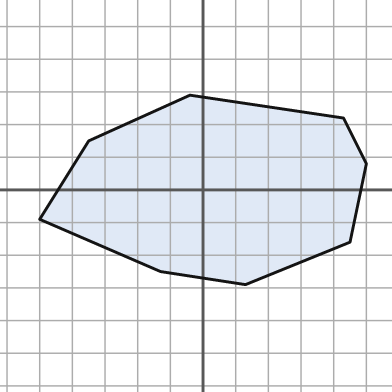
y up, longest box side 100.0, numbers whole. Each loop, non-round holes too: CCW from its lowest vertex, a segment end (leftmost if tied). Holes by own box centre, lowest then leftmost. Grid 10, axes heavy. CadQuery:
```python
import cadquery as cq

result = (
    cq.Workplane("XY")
    .moveTo(13.0, -29.0)
    .lineTo(45.0, -16.0)
    .lineTo(50.0, 8.0)
    .lineTo(43.0, 22.0)
    .lineTo(-4.0, 29.0)
    .lineTo(-35.0, 15.0)
    .lineTo(-50.0, -9.0)
    .lineTo(-13.0, -25.0)
    .close()
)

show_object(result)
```